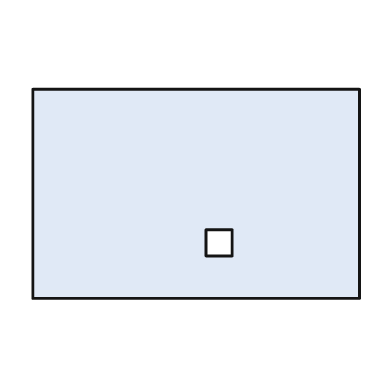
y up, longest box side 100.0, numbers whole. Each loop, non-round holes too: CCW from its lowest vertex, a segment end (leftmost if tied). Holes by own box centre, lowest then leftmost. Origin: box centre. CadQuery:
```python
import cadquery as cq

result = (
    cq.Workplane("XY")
    .moveTo(-50.0, -32.0)
    .lineTo(50.0, -32.0)
    .lineTo(50.0, 32.0)
    .lineTo(-50.0, 32.0)
    .close()
    .moveTo(3.0, -19.0)
    .lineTo(11.0, -19.0)
    .lineTo(11.0, -11.0)
    .lineTo(3.0, -11.0)
    .close()
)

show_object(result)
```